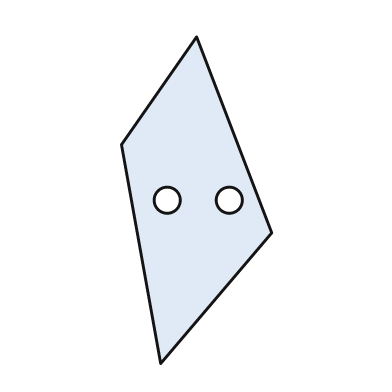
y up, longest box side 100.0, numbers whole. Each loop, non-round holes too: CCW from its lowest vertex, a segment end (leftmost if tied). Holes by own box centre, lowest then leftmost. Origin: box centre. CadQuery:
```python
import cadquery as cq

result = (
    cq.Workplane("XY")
    .moveTo(-11.0, -50.0)
    .lineTo(23.0, -10.0)
    .lineTo(0.0, 50.0)
    .lineTo(-23.0, 17.0)
    .close()
    .moveTo(-9.0, 0.0)
    .circle(4.0)
    .moveTo(10.0, 0.0)
    .circle(4.0)
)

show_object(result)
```